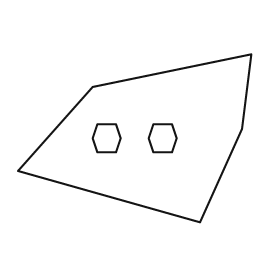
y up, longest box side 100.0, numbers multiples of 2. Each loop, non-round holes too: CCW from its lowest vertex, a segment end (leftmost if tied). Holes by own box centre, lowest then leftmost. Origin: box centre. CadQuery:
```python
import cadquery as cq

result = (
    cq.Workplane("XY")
    .moveTo(28.0, -36.0)
    .lineTo(46.0, 4.0)
    .lineTo(50.0, 36.0)
    .lineTo(-18.0, 22.0)
    .lineTo(-50.0, -14.0)
    .close()
    .moveTo(-16.0, -6.0)
    .lineTo(-8.0, -6.0)
    .lineTo(-6.0, 0.0)
    .lineTo(-8.0, 6.0)
    .lineTo(-16.0, 6.0)
    .lineTo(-18.0, 0.0)
    .close()
    .moveTo(8.0, -6.0)
    .lineTo(16.0, -6.0)
    .lineTo(18.0, 0.0)
    .lineTo(16.0, 6.0)
    .lineTo(8.0, 6.0)
    .lineTo(6.0, 0.0)
    .close()
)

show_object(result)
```